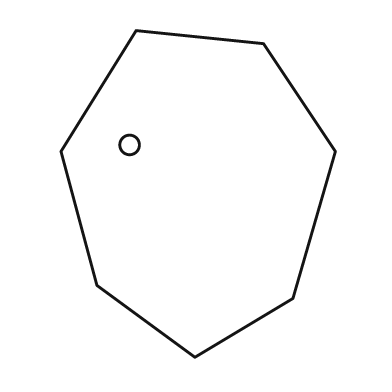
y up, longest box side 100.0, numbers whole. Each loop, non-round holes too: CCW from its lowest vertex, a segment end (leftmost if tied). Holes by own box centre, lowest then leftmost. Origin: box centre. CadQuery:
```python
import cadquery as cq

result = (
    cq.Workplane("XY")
    .moveTo(-1.0, -50.0)
    .lineTo(29.0, -32.0)
    .lineTo(42.0, 13.0)
    .lineTo(20.0, 46.0)
    .lineTo(-19.0, 50.0)
    .lineTo(-42.0, 13.0)
    .lineTo(-31.0, -28.0)
    .close()
    .moveTo(-21.0, 15.0)
    .circle(3.0)
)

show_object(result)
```